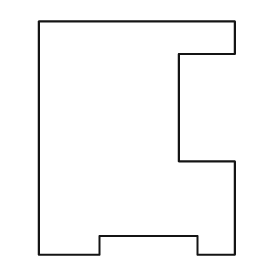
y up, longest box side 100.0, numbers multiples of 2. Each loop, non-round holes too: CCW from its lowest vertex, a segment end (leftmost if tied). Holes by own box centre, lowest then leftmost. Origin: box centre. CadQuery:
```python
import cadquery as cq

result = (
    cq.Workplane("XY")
    .moveTo(-42.0, -50.0)
    .lineTo(-16.0, -50.0)
    .lineTo(-16.0, -42.0)
    .lineTo(26.0, -42.0)
    .lineTo(26.0, -50.0)
    .lineTo(42.0, -50.0)
    .lineTo(42.0, -10.0)
    .lineTo(18.0, -10.0)
    .lineTo(18.0, 36.0)
    .lineTo(42.0, 36.0)
    .lineTo(42.0, 50.0)
    .lineTo(-42.0, 50.0)
    .close()
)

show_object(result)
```